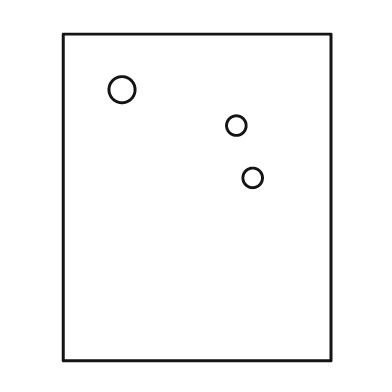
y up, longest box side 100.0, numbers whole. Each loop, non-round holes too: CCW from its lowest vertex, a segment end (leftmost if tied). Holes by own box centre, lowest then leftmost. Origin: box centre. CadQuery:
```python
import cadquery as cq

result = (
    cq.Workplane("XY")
    .moveTo(-41.0, -50.0)
    .lineTo(41.0, -50.0)
    .lineTo(41.0, 50.0)
    .lineTo(-41.0, 50.0)
    .close()
    .moveTo(17.0, 6.0)
    .circle(3.0)
    .moveTo(12.0, 22.0)
    .circle(3.0)
    .moveTo(-23.0, 33.0)
    .circle(4.0)
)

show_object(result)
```